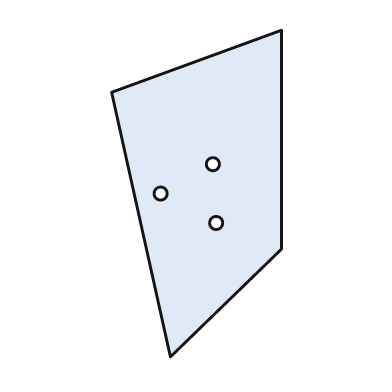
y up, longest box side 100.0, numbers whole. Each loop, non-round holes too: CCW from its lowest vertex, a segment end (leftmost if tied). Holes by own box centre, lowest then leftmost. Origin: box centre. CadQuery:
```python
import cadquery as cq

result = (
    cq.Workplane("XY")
    .moveTo(-8.0, -50.0)
    .lineTo(26.0, -17.0)
    .lineTo(26.0, 50.0)
    .lineTo(-26.0, 31.0)
    .close()
    .moveTo(6.0, -9.0)
    .circle(2.0)
    .moveTo(-11.0, 0.0)
    .circle(2.0)
    .moveTo(5.0, 9.0)
    .circle(2.0)
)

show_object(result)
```